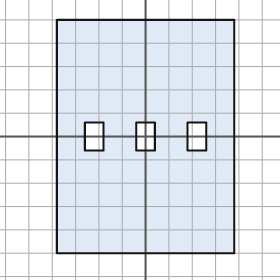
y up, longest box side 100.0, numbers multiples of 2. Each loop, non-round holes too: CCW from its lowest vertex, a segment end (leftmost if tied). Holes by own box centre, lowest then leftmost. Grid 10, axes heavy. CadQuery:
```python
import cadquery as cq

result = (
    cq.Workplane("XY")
    .moveTo(-38.0, -50.0)
    .lineTo(38.0, -50.0)
    .lineTo(38.0, 50.0)
    .lineTo(-38.0, 50.0)
    .close()
    .moveTo(-26.0, -6.0)
    .lineTo(-18.0, -6.0)
    .lineTo(-18.0, 6.0)
    .lineTo(-26.0, 6.0)
    .close()
    .moveTo(-4.0, -6.0)
    .lineTo(4.0, -6.0)
    .lineTo(4.0, 6.0)
    .lineTo(-4.0, 6.0)
    .close()
    .moveTo(18.0, -6.0)
    .lineTo(26.0, -6.0)
    .lineTo(26.0, 6.0)
    .lineTo(18.0, 6.0)
    .close()
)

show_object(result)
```